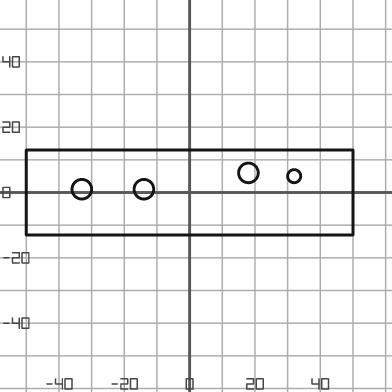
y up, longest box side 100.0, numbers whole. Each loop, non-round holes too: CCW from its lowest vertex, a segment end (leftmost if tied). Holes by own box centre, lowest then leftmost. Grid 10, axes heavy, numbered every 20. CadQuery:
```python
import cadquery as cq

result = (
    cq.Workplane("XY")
    .moveTo(-50.0, -13.0)
    .lineTo(50.0, -13.0)
    .lineTo(50.0, 13.0)
    .lineTo(-50.0, 13.0)
    .close()
    .moveTo(-33.0, 1.0)
    .circle(3.0)
    .moveTo(-14.0, 1.0)
    .circle(3.0)
    .moveTo(32.0, 5.0)
    .circle(2.0)
    .moveTo(18.0, 6.0)
    .circle(3.0)
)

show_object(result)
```